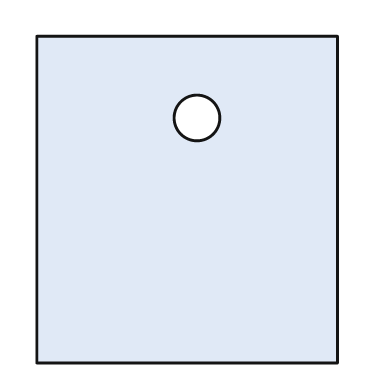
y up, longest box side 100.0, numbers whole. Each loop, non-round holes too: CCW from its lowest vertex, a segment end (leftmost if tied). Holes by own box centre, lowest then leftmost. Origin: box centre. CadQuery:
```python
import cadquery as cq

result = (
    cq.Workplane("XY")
    .moveTo(-46.0, -50.0)
    .lineTo(46.0, -50.0)
    .lineTo(46.0, 50.0)
    .lineTo(-46.0, 50.0)
    .close()
    .moveTo(3.0, 25.0)
    .circle(7.0)
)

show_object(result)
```